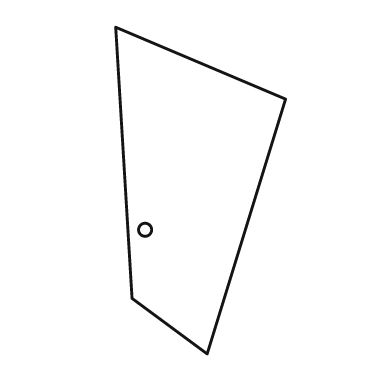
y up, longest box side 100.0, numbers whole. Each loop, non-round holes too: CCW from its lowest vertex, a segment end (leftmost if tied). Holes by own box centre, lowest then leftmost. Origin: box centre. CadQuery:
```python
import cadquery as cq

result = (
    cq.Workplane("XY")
    .moveTo(2.0, -50.0)
    .lineTo(26.0, 28.0)
    .lineTo(-26.0, 50.0)
    .lineTo(-21.0, -33.0)
    .close()
    .moveTo(-17.0, -12.0)
    .circle(2.0)
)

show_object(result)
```